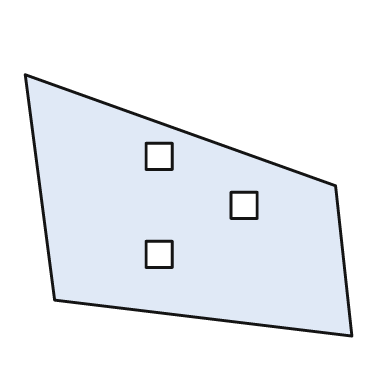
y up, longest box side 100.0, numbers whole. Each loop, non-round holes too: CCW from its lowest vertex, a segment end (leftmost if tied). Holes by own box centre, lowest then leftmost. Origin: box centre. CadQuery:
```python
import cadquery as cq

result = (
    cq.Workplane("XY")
    .moveTo(50.0, -40.0)
    .lineTo(45.0, 6.0)
    .lineTo(-50.0, 40.0)
    .lineTo(-41.0, -29.0)
    .close()
    .moveTo(-13.0, -19.0)
    .lineTo(-5.0, -19.0)
    .lineTo(-5.0, -11.0)
    .lineTo(-13.0, -11.0)
    .close()
    .moveTo(13.0, -4.0)
    .lineTo(21.0, -4.0)
    .lineTo(21.0, 4.0)
    .lineTo(13.0, 4.0)
    .close()
    .moveTo(-13.0, 11.0)
    .lineTo(-5.0, 11.0)
    .lineTo(-5.0, 19.0)
    .lineTo(-13.0, 19.0)
    .close()
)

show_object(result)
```